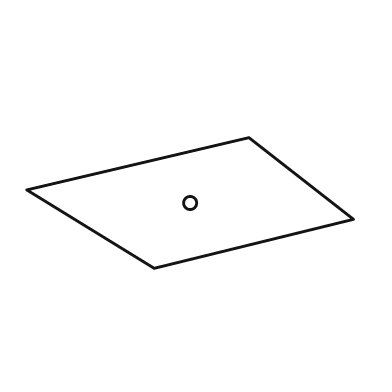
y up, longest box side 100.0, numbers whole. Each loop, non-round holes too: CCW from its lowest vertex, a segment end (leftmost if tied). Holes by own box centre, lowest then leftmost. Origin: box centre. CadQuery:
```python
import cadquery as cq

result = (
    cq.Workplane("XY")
    .moveTo(-11.0, -20.0)
    .lineTo(50.0, -5.0)
    .lineTo(18.0, 20.0)
    .lineTo(-50.0, 4.0)
    .close()
    .moveTo(0.0, 0.0)
    .circle(2.0)
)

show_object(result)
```